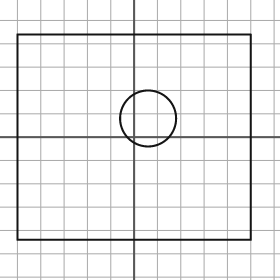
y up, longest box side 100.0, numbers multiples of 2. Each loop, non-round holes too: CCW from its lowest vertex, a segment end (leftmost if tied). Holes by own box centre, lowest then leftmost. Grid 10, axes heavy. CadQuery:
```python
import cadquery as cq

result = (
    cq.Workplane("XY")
    .moveTo(-50.0, -44.0)
    .lineTo(50.0, -44.0)
    .lineTo(50.0, 44.0)
    .lineTo(-50.0, 44.0)
    .close()
    .moveTo(6.0, 8.0)
    .circle(12.0)
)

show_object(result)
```